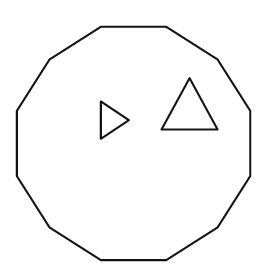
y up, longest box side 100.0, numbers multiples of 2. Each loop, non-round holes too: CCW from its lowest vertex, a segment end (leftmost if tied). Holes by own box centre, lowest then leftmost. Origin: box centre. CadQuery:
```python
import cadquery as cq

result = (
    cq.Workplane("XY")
    .moveTo(-14.0, -50.0)
    .lineTo(14.0, -50.0)
    .lineTo(36.0, -36.0)
    .lineTo(50.0, -14.0)
    .lineTo(50.0, 14.0)
    .lineTo(36.0, 36.0)
    .lineTo(14.0, 50.0)
    .lineTo(-14.0, 50.0)
    .lineTo(-36.0, 36.0)
    .lineTo(-50.0, 14.0)
    .lineTo(-50.0, -14.0)
    .lineTo(-36.0, -36.0)
    .close()
    .moveTo(-14.0, 2.0)
    .lineTo(-2.0, 10.0)
    .lineTo(-14.0, 18.0)
    .close()
    .moveTo(12.0, 6.0)
    .lineTo(36.0, 6.0)
    .lineTo(24.0, 28.0)
    .close()
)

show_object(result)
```